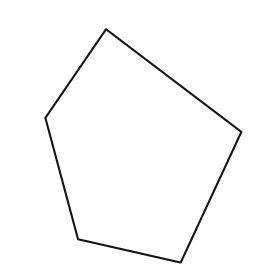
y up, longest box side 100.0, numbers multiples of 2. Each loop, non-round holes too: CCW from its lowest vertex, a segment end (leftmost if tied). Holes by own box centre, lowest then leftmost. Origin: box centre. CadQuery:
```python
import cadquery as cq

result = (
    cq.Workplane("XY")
    .moveTo(16.0, -50.0)
    .lineTo(42.0, 6.0)
    .lineTo(-16.0, 50.0)
    .lineTo(-42.0, 12.0)
    .lineTo(-28.0, -40.0)
    .close()
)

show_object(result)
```